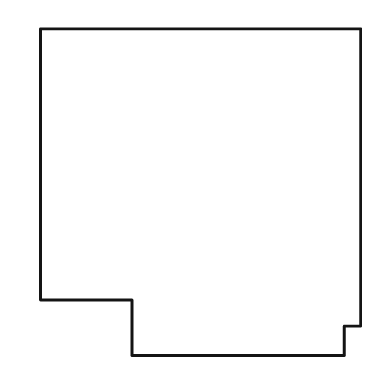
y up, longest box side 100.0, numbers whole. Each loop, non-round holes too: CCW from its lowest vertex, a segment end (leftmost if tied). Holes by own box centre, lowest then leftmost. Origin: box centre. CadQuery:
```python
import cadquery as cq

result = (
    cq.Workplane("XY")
    .moveTo(-21.0, -50.0)
    .lineTo(44.0, -50.0)
    .lineTo(44.0, -41.0)
    .lineTo(49.0, -41.0)
    .lineTo(49.0, 50.0)
    .lineTo(-49.0, 50.0)
    .lineTo(-49.0, -33.0)
    .lineTo(-21.0, -33.0)
    .close()
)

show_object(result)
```